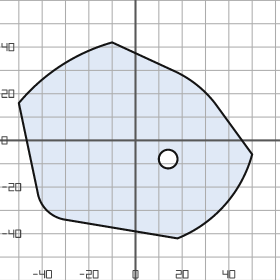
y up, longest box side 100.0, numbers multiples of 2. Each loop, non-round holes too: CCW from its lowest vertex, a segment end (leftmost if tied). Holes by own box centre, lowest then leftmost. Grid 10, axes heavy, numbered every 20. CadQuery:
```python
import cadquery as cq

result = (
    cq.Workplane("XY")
    .moveTo(18.0, -42.0)
    .threePointArc((38.0, -28.0), (50.0, -6.0))
    .lineTo(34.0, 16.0)
    .threePointArc((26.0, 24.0), (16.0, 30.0))
    .lineTo(-10.0, 42.0)
    .threePointArc((-32.0, 32.0), (-50.0, 16.0))
    .lineTo(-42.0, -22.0)
    .threePointArc((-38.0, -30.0), (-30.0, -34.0))
    .close()
    .moveTo(14.0, -8.0)
    .circle(4.0)
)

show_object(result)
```